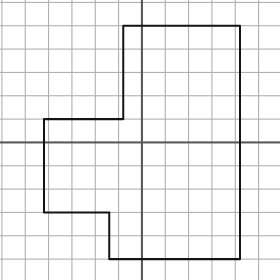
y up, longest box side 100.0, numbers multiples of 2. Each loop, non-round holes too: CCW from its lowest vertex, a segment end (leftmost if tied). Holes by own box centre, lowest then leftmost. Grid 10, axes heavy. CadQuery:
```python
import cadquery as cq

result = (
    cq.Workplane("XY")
    .moveTo(-14.0, -50.0)
    .lineTo(42.0, -50.0)
    .lineTo(42.0, 50.0)
    .lineTo(-8.0, 50.0)
    .lineTo(-8.0, 10.0)
    .lineTo(-42.0, 10.0)
    .lineTo(-42.0, -30.0)
    .lineTo(-14.0, -30.0)
    .close()
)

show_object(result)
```